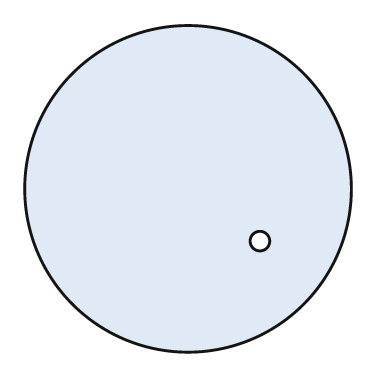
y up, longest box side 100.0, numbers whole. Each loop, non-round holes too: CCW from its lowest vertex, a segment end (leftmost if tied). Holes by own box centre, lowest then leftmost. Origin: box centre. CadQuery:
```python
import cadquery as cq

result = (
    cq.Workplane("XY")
    .moveTo(0.0, 0.0)
    .circle(50.0)
    .moveTo(22.0, -16.0)
    .circle(3.0)
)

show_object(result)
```